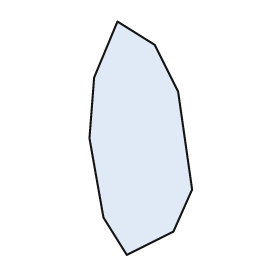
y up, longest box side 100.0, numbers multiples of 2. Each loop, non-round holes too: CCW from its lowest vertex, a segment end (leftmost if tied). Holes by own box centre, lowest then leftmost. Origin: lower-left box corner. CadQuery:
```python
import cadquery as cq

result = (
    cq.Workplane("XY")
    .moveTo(16.0, 0.0)
    .lineTo(36.0, 10.0)
    .lineTo(44.0, 28.0)
    .lineTo(38.0, 70.0)
    .lineTo(28.0, 90.0)
    .lineTo(12.0, 100.0)
    .lineTo(2.0, 76.0)
    .lineTo(0.0, 50.0)
    .lineTo(6.0, 16.0)
    .close()
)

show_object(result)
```